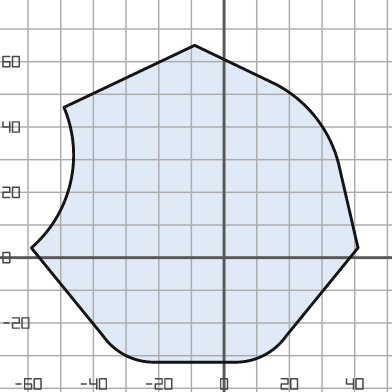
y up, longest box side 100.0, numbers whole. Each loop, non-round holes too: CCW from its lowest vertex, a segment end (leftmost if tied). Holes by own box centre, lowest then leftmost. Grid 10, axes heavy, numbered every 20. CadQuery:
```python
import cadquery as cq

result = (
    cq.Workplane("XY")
    .moveTo(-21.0, -32.0)
    .lineTo(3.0, -32.0)
    .threePointArc((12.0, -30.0), (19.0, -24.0))
    .lineTo(41.0, 3.0)
    .lineTo(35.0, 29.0)
    .threePointArc((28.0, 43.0), (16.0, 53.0))
    .lineTo(-9.0, 65.0)
    .lineTo(-49.0, 46.0)
    .threePointArc((-47.0, 23.0), (-59.0, 3.0))
    .lineTo(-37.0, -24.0)
    .threePointArc((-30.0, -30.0), (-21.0, -32.0))
    .close()
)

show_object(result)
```